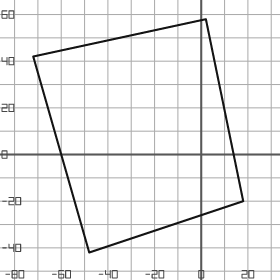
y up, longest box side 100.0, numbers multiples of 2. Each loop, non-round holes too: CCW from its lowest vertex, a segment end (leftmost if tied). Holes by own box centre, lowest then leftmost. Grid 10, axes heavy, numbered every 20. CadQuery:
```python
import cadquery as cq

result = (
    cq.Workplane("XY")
    .moveTo(-48.0, -42.0)
    .lineTo(18.0, -20.0)
    .lineTo(2.0, 58.0)
    .lineTo(-72.0, 42.0)
    .close()
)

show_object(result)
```